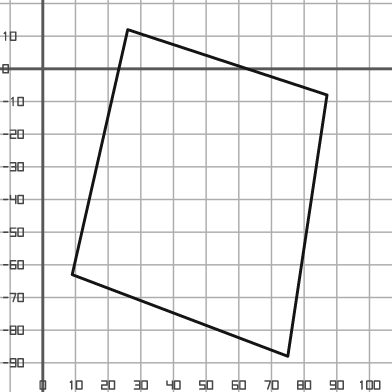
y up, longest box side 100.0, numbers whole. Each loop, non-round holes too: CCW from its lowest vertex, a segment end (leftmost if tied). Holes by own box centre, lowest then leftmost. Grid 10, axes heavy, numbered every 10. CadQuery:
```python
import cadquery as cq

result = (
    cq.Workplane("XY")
    .moveTo(75.0, -88.0)
    .lineTo(87.0, -8.0)
    .lineTo(26.0, 12.0)
    .lineTo(9.0, -63.0)
    .close()
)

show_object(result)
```